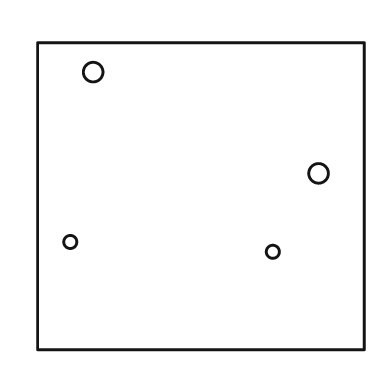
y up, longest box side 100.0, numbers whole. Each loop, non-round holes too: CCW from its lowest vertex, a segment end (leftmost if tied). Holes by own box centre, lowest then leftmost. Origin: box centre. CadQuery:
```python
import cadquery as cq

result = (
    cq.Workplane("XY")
    .moveTo(-50.0, -47.0)
    .lineTo(50.0, -47.0)
    .lineTo(50.0, 47.0)
    .lineTo(-50.0, 47.0)
    .close()
    .moveTo(22.0, -17.0)
    .circle(2.0)
    .moveTo(-40.0, -14.0)
    .circle(2.0)
    .moveTo(36.0, 7.0)
    .circle(3.0)
    .moveTo(-33.0, 38.0)
    .circle(3.0)
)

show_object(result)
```